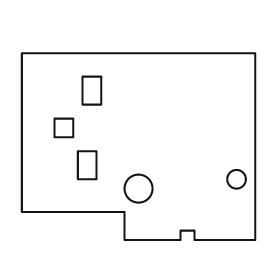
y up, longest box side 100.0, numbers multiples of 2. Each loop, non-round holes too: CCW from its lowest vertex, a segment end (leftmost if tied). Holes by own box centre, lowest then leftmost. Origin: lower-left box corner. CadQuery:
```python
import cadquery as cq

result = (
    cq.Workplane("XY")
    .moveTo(44.0, 0.0)
    .lineTo(68.0, 0.0)
    .lineTo(68.0, 4.0)
    .lineTo(74.0, 4.0)
    .lineTo(74.0, 0.0)
    .lineTo(100.0, 0.0)
    .lineTo(100.0, 80.0)
    .lineTo(0.0, 80.0)
    .lineTo(0.0, 12.0)
    .lineTo(44.0, 12.0)
    .close()
    .moveTo(50.0, 22.0)
    .circle(6.0)
    .moveTo(92.0, 26.0)
    .circle(4.0)
    .moveTo(24.0, 26.0)
    .lineTo(32.0, 26.0)
    .lineTo(32.0, 38.0)
    .lineTo(24.0, 38.0)
    .close()
    .moveTo(14.0, 44.0)
    .lineTo(22.0, 44.0)
    .lineTo(22.0, 52.0)
    .lineTo(14.0, 52.0)
    .close()
    .moveTo(26.0, 58.0)
    .lineTo(34.0, 58.0)
    .lineTo(34.0, 70.0)
    .lineTo(26.0, 70.0)
    .close()
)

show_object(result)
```